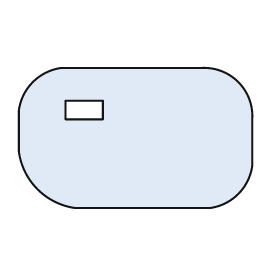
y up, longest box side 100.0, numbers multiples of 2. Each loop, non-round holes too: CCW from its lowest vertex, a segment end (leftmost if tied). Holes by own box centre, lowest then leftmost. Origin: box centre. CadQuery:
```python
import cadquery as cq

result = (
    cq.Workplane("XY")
    .moveTo(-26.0, -30.0)
    .lineTo(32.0, -30.0)
    .threePointArc((44.0, -24.0), (50.0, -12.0))
    .lineTo(50.0, 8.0)
    .threePointArc((44.0, 24.0), (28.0, 30.0))
    .lineTo(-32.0, 30.0)
    .threePointArc((-44.0, 24.0), (-50.0, 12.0))
    .lineTo(-50.0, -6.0)
    .threePointArc((-42.0, -22.0), (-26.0, -30.0))
    .close()
    .moveTo(-30.0, 8.0)
    .lineTo(-14.0, 8.0)
    .lineTo(-14.0, 16.0)
    .lineTo(-30.0, 16.0)
    .close()
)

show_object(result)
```